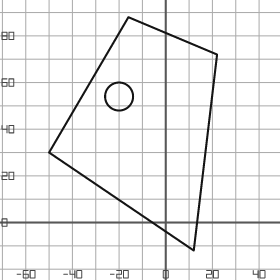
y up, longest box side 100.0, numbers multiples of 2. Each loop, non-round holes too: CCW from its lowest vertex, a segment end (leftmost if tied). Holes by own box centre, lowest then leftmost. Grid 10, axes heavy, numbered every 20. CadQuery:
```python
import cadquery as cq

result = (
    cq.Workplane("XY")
    .moveTo(12.0, -12.0)
    .lineTo(22.0, 72.0)
    .lineTo(-16.0, 88.0)
    .lineTo(-50.0, 30.0)
    .close()
    .moveTo(-20.0, 54.0)
    .circle(6.0)
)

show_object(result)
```